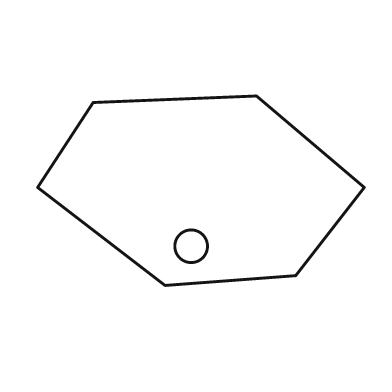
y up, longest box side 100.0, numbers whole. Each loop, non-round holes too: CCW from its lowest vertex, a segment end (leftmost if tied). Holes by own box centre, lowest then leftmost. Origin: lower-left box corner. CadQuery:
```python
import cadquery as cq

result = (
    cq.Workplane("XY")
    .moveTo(39.0, 0.0)
    .lineTo(79.0, 3.0)
    .lineTo(100.0, 30.0)
    .lineTo(67.0, 58.0)
    .lineTo(17.0, 56.0)
    .lineTo(0.0, 30.0)
    .close()
    .moveTo(47.0, 12.0)
    .circle(5.0)
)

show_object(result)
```